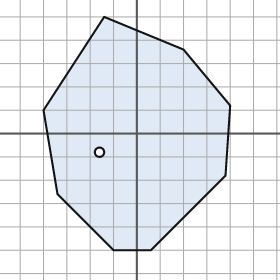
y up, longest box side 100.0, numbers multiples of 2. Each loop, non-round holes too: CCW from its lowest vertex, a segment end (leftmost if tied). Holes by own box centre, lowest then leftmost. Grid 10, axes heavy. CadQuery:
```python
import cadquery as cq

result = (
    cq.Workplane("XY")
    .moveTo(-10.0, -50.0)
    .lineTo(6.0, -50.0)
    .lineTo(38.0, -18.0)
    .lineTo(40.0, 12.0)
    .lineTo(20.0, 36.0)
    .lineTo(-14.0, 50.0)
    .lineTo(-40.0, 10.0)
    .lineTo(-34.0, -26.0)
    .close()
    .moveTo(-16.0, -8.0)
    .circle(2.0)
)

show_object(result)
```